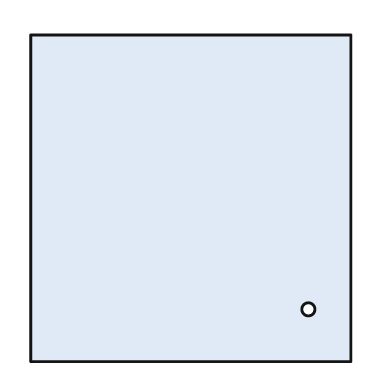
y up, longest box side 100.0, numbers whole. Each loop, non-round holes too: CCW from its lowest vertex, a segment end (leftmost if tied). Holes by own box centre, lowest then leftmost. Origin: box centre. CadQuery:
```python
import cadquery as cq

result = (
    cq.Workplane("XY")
    .moveTo(-49.0, -50.0)
    .lineTo(49.0, -50.0)
    .lineTo(49.0, 50.0)
    .lineTo(-49.0, 50.0)
    .close()
    .moveTo(36.0, -34.0)
    .circle(2.0)
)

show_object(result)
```